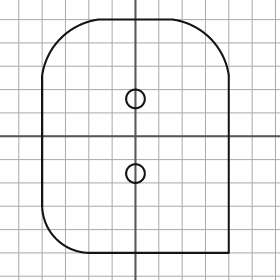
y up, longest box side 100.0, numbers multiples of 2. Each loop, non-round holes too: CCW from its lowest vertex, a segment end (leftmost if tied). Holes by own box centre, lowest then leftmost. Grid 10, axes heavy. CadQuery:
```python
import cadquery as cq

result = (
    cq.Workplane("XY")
    .moveTo(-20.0, -50.0)
    .lineTo(40.0, -50.0)
    .lineTo(40.0, 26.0)
    .threePointArc((32.0, 42.0), (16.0, 50.0))
    .lineTo(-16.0, 50.0)
    .threePointArc((-32.0, 42.0), (-40.0, 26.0))
    .lineTo(-40.0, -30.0)
    .threePointArc((-34.0, -44.0), (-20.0, -50.0))
    .close()
    .moveTo(0.0, -16.0)
    .circle(4.0)
    .moveTo(0.0, 16.0)
    .circle(4.0)
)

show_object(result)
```